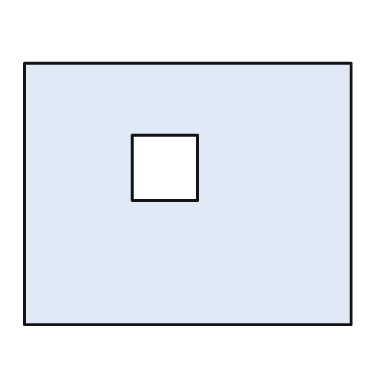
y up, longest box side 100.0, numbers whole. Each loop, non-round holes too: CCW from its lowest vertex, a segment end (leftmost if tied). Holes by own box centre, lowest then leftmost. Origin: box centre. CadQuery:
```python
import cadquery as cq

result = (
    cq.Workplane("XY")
    .moveTo(-50.0, -40.0)
    .lineTo(50.0, -40.0)
    .lineTo(50.0, 40.0)
    .lineTo(-50.0, 40.0)
    .close()
    .moveTo(-17.0, -2.0)
    .lineTo(3.0, -2.0)
    .lineTo(3.0, 18.0)
    .lineTo(-17.0, 18.0)
    .close()
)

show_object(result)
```